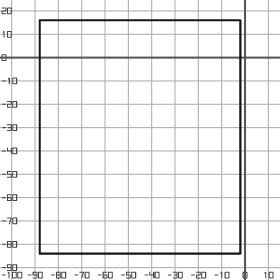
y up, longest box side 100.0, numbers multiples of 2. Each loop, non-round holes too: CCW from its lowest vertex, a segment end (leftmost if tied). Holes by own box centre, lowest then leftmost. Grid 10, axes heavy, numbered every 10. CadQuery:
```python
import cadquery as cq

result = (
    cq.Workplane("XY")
    .moveTo(-88.0, -84.0)
    .lineTo(-2.0, -84.0)
    .lineTo(-2.0, 16.0)
    .lineTo(-88.0, 16.0)
    .close()
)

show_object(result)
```